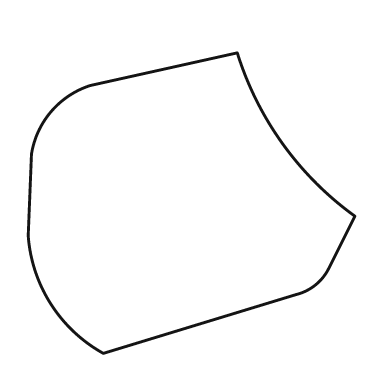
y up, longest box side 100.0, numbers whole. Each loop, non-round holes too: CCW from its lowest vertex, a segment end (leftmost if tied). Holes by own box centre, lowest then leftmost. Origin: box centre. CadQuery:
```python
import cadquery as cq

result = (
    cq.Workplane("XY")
    .moveTo(-27.0, -46.0)
    .lineTo(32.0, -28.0)
    .threePointArc((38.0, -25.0), (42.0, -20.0))
    .lineTo(50.0, -4.0)
    .threePointArc((28.0, 18.0), (14.0, 46.0))
    .lineTo(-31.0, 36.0)
    .threePointArc((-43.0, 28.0), (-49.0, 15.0))
    .lineTo(-50.0, -10.0)
    .threePointArc((-43.0, -31.0), (-27.0, -46.0))
    .close()
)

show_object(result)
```